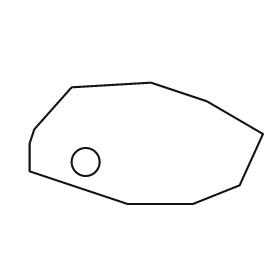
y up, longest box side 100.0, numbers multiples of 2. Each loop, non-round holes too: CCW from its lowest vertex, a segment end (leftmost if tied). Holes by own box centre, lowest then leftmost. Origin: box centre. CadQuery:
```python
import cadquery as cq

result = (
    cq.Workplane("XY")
    .moveTo(-8.0, -26.0)
    .lineTo(20.0, -26.0)
    .lineTo(40.0, -18.0)
    .lineTo(50.0, 4.0)
    .lineTo(26.0, 18.0)
    .lineTo(2.0, 26.0)
    .lineTo(-32.0, 24.0)
    .lineTo(-48.0, 6.0)
    .lineTo(-50.0, 0.0)
    .lineTo(-50.0, -12.0)
    .close()
    .moveTo(-26.0, -8.0)
    .circle(6.0)
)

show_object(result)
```